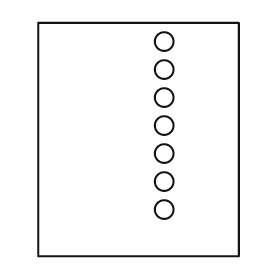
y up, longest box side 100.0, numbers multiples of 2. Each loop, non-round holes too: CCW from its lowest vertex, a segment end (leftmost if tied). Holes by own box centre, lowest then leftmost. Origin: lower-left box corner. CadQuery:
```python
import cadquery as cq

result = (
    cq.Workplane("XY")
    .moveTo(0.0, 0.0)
    .lineTo(86.0, 0.0)
    .lineTo(86.0, 100.0)
    .lineTo(0.0, 100.0)
    .close()
    .moveTo(54.0, 20.0)
    .circle(4.0)
    .moveTo(54.0, 32.0)
    .circle(4.0)
    .moveTo(54.0, 44.0)
    .circle(4.0)
    .moveTo(54.0, 56.0)
    .circle(4.0)
    .moveTo(54.0, 68.0)
    .circle(4.0)
    .moveTo(54.0, 80.0)
    .circle(4.0)
    .moveTo(54.0, 92.0)
    .circle(4.0)
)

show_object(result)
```